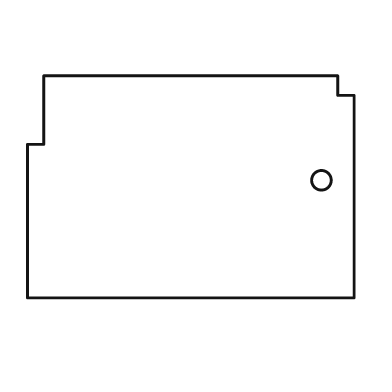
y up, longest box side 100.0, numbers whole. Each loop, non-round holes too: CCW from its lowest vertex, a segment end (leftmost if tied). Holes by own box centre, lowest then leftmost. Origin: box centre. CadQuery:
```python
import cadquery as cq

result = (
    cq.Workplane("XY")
    .moveTo(-50.0, -34.0)
    .lineTo(50.0, -34.0)
    .lineTo(50.0, 28.0)
    .lineTo(45.0, 28.0)
    .lineTo(45.0, 34.0)
    .lineTo(-45.0, 34.0)
    .lineTo(-45.0, 13.0)
    .lineTo(-50.0, 13.0)
    .close()
    .moveTo(40.0, 2.0)
    .circle(3.0)
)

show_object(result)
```